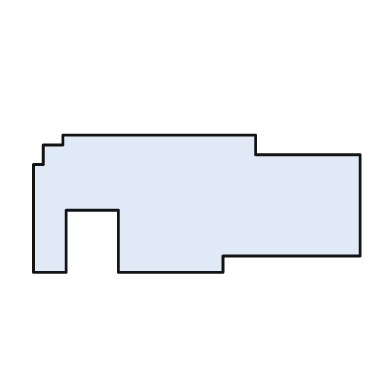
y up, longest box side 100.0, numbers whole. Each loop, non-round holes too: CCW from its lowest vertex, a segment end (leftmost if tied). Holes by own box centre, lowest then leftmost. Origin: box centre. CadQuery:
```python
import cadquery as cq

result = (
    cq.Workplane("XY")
    .moveTo(-50.0, -21.0)
    .lineTo(-40.0, -21.0)
    .lineTo(-40.0, -2.0)
    .lineTo(-24.0, -2.0)
    .lineTo(-24.0, -21.0)
    .lineTo(8.0, -21.0)
    .lineTo(8.0, -16.0)
    .lineTo(50.0, -16.0)
    .lineTo(50.0, 15.0)
    .lineTo(18.0, 15.0)
    .lineTo(18.0, 21.0)
    .lineTo(-41.0, 21.0)
    .lineTo(-41.0, 18.0)
    .lineTo(-47.0, 18.0)
    .lineTo(-47.0, 12.0)
    .lineTo(-50.0, 12.0)
    .close()
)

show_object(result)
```